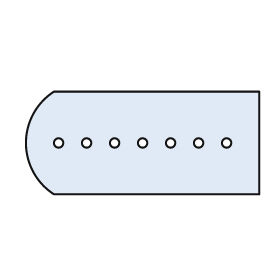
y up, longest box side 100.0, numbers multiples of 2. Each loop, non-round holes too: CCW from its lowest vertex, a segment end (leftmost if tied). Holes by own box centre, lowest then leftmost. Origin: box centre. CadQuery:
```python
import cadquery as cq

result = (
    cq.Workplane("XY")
    .moveTo(-38.0, -22.0)
    .lineTo(50.0, -22.0)
    .lineTo(50.0, 22.0)
    .lineTo(-38.0, 22.0)
    .threePointArc((-50.0, 0.0), (-38.0, -22.0))
    .close()
    .moveTo(-36.0, 0.0)
    .circle(2.0)
    .moveTo(-24.0, 0.0)
    .circle(2.0)
    .moveTo(-12.0, 0.0)
    .circle(2.0)
    .moveTo(0.0, 0.0)
    .circle(2.0)
    .moveTo(12.0, 0.0)
    .circle(2.0)
    .moveTo(24.0, 0.0)
    .circle(2.0)
    .moveTo(36.0, 0.0)
    .circle(2.0)
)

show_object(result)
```